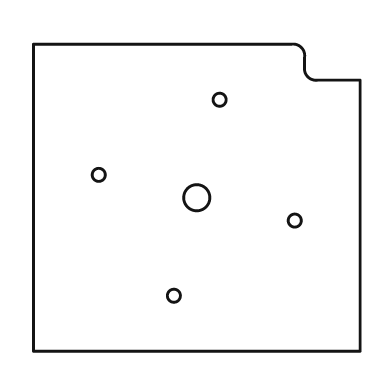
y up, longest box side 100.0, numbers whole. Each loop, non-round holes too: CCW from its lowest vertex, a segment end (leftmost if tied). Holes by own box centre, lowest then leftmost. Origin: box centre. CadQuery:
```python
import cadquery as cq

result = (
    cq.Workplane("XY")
    .moveTo(-50.0, -47.0)
    .lineTo(50.0, -47.0)
    .lineTo(50.0, 36.0)
    .lineTo(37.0, 36.0)
    .threePointArc((34.0, 37.0), (33.0, 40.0))
    .lineTo(33.0, 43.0)
    .threePointArc((32.0, 46.0), (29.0, 47.0))
    .lineTo(-50.0, 47.0)
    .close()
    .moveTo(-7.0, -30.0)
    .circle(2.0)
    .moveTo(30.0, -7.0)
    .circle(2.0)
    .moveTo(0.0, 0.0)
    .circle(4.0)
    .moveTo(-30.0, 7.0)
    .circle(2.0)
    .moveTo(7.0, 30.0)
    .circle(2.0)
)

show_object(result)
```